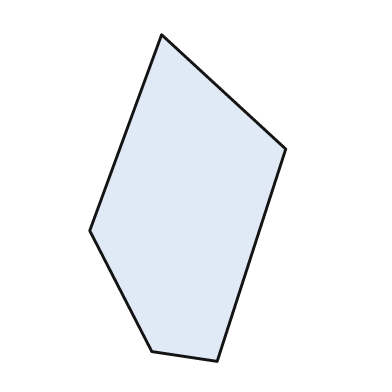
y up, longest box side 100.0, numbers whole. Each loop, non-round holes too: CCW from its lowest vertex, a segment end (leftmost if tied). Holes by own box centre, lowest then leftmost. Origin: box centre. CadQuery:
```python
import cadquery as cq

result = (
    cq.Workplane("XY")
    .moveTo(9.0, -50.0)
    .lineTo(30.0, 15.0)
    .lineTo(-8.0, 50.0)
    .lineTo(-30.0, -10.0)
    .lineTo(-11.0, -47.0)
    .close()
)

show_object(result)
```